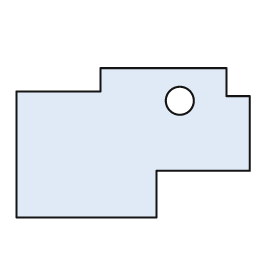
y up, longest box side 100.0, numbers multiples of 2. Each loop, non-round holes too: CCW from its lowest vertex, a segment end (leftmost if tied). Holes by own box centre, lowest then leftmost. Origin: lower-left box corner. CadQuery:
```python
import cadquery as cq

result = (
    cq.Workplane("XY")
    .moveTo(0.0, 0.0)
    .lineTo(60.0, 0.0)
    .lineTo(60.0, 20.0)
    .lineTo(100.0, 20.0)
    .lineTo(100.0, 52.0)
    .lineTo(90.0, 52.0)
    .lineTo(90.0, 64.0)
    .lineTo(36.0, 64.0)
    .lineTo(36.0, 54.0)
    .lineTo(0.0, 54.0)
    .close()
    .moveTo(70.0, 50.0)
    .circle(6.0)
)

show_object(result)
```